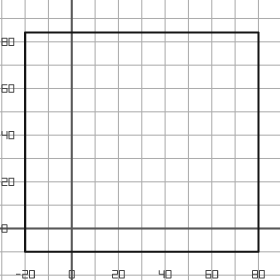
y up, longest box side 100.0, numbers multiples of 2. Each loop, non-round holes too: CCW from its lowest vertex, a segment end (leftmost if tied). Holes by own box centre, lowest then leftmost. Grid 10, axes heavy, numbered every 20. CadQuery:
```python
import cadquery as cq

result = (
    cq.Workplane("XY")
    .moveTo(-20.0, -10.0)
    .lineTo(80.0, -10.0)
    .lineTo(80.0, 84.0)
    .lineTo(-20.0, 84.0)
    .close()
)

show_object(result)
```